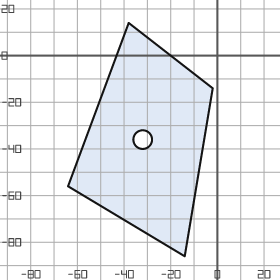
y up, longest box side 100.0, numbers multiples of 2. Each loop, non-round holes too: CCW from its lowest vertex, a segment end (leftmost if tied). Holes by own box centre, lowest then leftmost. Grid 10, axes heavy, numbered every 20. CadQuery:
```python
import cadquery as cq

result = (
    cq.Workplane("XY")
    .moveTo(-14.0, -86.0)
    .lineTo(-2.0, -14.0)
    .lineTo(-38.0, 14.0)
    .lineTo(-64.0, -56.0)
    .close()
    .moveTo(-32.0, -36.0)
    .circle(4.0)
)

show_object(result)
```